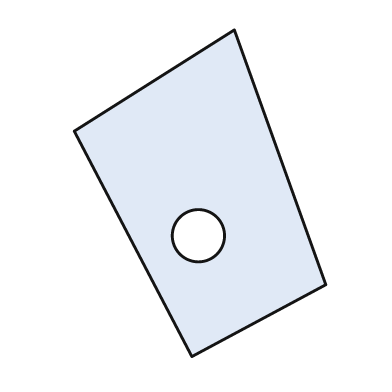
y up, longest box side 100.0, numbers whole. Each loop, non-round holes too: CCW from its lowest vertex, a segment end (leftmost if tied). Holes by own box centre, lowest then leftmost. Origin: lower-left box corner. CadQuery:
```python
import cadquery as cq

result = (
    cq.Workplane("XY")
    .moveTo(36.0, 0.0)
    .lineTo(77.0, 22.0)
    .lineTo(49.0, 100.0)
    .lineTo(0.0, 69.0)
    .close()
    .moveTo(38.0, 37.0)
    .circle(8.0)
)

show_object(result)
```